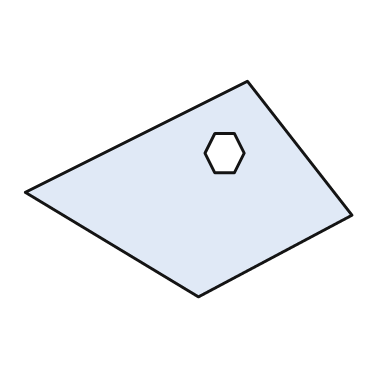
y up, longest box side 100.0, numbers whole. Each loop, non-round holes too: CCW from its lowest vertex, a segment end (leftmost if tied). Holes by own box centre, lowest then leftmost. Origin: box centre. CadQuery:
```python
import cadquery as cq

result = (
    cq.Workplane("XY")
    .moveTo(3.0, -33.0)
    .lineTo(50.0, -8.0)
    .lineTo(18.0, 33.0)
    .lineTo(-50.0, -1.0)
    .close()
    .moveTo(8.0, 5.0)
    .lineTo(14.0, 5.0)
    .lineTo(17.0, 11.0)
    .lineTo(14.0, 17.0)
    .lineTo(8.0, 17.0)
    .lineTo(5.0, 11.0)
    .close()
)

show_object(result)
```